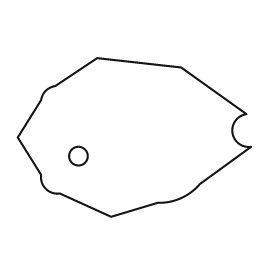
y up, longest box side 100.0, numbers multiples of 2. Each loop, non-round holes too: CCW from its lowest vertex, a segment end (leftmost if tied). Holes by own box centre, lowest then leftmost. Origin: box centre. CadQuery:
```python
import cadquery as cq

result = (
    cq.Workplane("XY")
    .moveTo(-10.0, -34.0)
    .lineTo(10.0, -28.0)
    .threePointArc((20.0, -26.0), (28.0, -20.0))
    .lineTo(50.0, -4.0)
    .threePointArc((42.0, 2.0), (48.0, 10.0))
    .lineTo(20.0, 30.0)
    .lineTo(-16.0, 34.0)
    .lineTo(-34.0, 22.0)
    .threePointArc((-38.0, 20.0), (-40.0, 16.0))
    .lineTo(-50.0, 0.0)
    .lineTo(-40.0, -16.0)
    .threePointArc((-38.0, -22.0), (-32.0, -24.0))
    .close()
    .moveTo(-24.0, -8.0)
    .circle(4.0)
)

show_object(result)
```